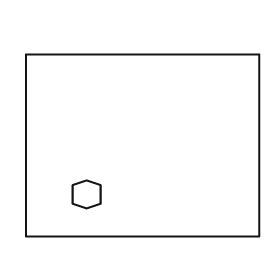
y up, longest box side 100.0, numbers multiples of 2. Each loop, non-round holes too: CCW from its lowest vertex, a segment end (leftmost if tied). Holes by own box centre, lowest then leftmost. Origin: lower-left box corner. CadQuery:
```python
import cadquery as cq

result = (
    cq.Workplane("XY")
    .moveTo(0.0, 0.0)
    .lineTo(100.0, 0.0)
    .lineTo(100.0, 78.0)
    .lineTo(0.0, 78.0)
    .close()
    .moveTo(26.0, 12.0)
    .lineTo(32.0, 14.0)
    .lineTo(32.0, 22.0)
    .lineTo(26.0, 24.0)
    .lineTo(20.0, 22.0)
    .lineTo(20.0, 14.0)
    .close()
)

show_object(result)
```